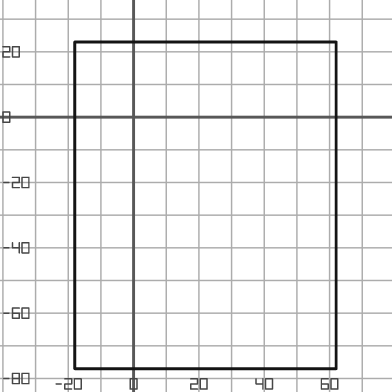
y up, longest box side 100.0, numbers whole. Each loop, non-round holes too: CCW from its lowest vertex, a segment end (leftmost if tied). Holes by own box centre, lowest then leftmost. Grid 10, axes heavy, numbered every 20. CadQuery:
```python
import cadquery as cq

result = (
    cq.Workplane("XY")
    .moveTo(-18.0, -77.0)
    .lineTo(62.0, -77.0)
    .lineTo(62.0, 23.0)
    .lineTo(-18.0, 23.0)
    .close()
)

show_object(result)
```